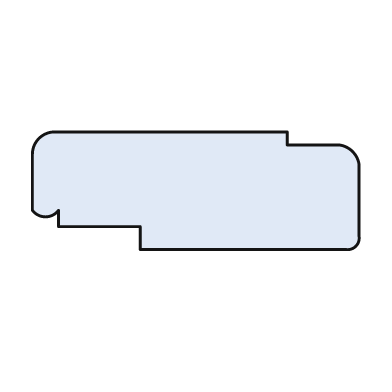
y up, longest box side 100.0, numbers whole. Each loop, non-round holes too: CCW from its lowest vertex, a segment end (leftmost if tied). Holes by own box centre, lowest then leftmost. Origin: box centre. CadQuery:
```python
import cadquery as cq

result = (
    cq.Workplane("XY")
    .moveTo(-17.0, -18.0)
    .lineTo(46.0, -18.0)
    .threePointArc((49.0, -17.0), (50.0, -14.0))
    .lineTo(50.0, 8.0)
    .threePointArc((48.0, 12.0), (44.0, 14.0))
    .lineTo(28.0, 14.0)
    .lineTo(28.0, 18.0)
    .lineTo(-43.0, 18.0)
    .threePointArc((-48.0, 16.0), (-50.0, 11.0))
    .lineTo(-50.0, -6.0)
    .threePointArc((-46.0, -8.0), (-42.0, -6.0))
    .lineTo(-42.0, -11.0)
    .lineTo(-17.0, -11.0)
    .close()
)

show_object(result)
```